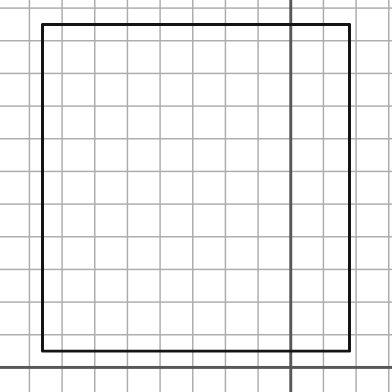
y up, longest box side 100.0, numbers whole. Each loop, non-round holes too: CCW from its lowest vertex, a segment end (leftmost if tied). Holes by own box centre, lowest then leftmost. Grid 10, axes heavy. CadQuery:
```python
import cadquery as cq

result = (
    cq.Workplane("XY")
    .moveTo(-76.0, 5.0)
    .lineTo(18.0, 5.0)
    .lineTo(18.0, 105.0)
    .lineTo(-76.0, 105.0)
    .close()
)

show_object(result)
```